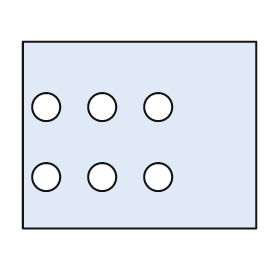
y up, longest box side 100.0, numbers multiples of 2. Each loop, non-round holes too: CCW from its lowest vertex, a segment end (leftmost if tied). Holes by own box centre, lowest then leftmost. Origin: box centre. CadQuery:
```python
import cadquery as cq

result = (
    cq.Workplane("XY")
    .moveTo(-50.0, -40.0)
    .lineTo(50.0, -40.0)
    .lineTo(50.0, 40.0)
    .lineTo(-50.0, 40.0)
    .close()
    .moveTo(-40.0, -18.0)
    .circle(6.0)
    .moveTo(-16.0, -18.0)
    .circle(6.0)
    .moveTo(8.0, -18.0)
    .circle(6.0)
    .moveTo(-40.0, 12.0)
    .circle(6.0)
    .moveTo(-16.0, 12.0)
    .circle(6.0)
    .moveTo(8.0, 12.0)
    .circle(6.0)
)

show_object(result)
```